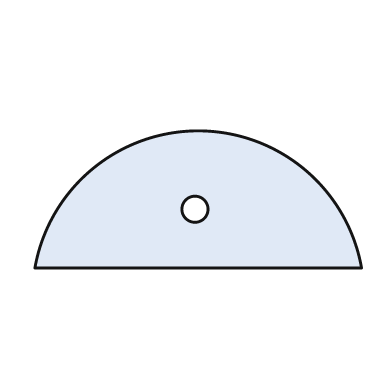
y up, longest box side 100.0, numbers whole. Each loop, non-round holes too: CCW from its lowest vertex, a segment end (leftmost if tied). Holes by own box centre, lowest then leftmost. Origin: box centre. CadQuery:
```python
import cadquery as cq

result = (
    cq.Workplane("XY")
    .moveTo(-50.0, -21.0)
    .lineTo(50.0, -21.0)
    .threePointArc((0.0, 21.0), (-50.0, -21.0))
    .close()
    .moveTo(-1.0, -3.0)
    .circle(4.0)
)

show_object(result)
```